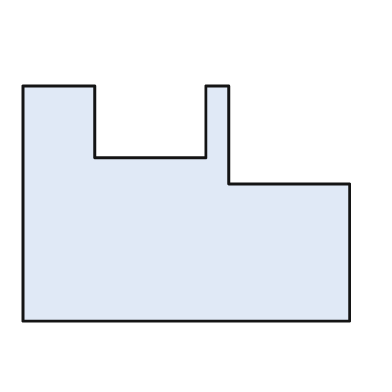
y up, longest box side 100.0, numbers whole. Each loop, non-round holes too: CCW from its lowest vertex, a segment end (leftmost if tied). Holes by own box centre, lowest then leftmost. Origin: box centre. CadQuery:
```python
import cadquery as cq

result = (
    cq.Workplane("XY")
    .moveTo(-50.0, -36.0)
    .lineTo(50.0, -36.0)
    .lineTo(50.0, 6.0)
    .lineTo(13.0, 6.0)
    .lineTo(13.0, 36.0)
    .lineTo(6.0, 36.0)
    .lineTo(6.0, 14.0)
    .lineTo(-28.0, 14.0)
    .lineTo(-28.0, 36.0)
    .lineTo(-50.0, 36.0)
    .close()
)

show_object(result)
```